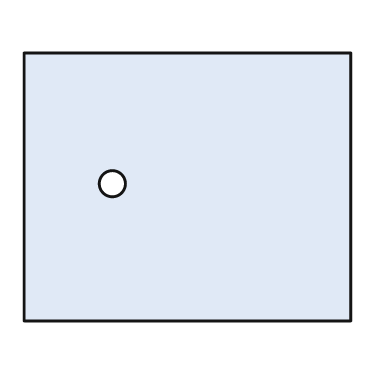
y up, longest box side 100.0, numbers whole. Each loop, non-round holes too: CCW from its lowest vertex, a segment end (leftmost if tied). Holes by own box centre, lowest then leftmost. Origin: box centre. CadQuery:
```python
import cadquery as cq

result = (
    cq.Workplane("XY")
    .moveTo(-50.0, -41.0)
    .lineTo(50.0, -41.0)
    .lineTo(50.0, 41.0)
    .lineTo(-50.0, 41.0)
    .close()
    .moveTo(-23.0, 1.0)
    .circle(4.0)
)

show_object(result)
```